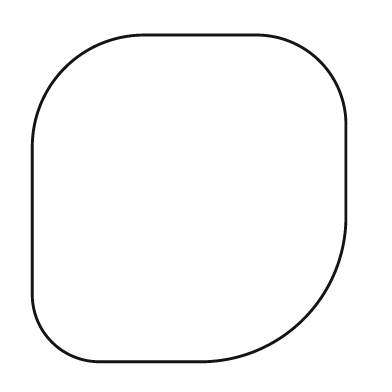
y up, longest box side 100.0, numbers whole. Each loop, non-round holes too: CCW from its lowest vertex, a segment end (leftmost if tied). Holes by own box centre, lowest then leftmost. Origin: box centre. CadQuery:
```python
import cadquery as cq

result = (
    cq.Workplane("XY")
    .moveTo(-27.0, -50.0)
    .lineTo(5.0, -50.0)
    .threePointArc((35.0, -37.0), (48.0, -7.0))
    .lineTo(48.0, 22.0)
    .threePointArc((40.0, 42.0), (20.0, 50.0))
    .lineTo(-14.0, 50.0)
    .threePointArc((-38.0, 40.0), (-48.0, 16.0))
    .lineTo(-48.0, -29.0)
    .threePointArc((-42.0, -44.0), (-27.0, -50.0))
    .close()
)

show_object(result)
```